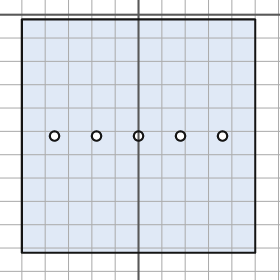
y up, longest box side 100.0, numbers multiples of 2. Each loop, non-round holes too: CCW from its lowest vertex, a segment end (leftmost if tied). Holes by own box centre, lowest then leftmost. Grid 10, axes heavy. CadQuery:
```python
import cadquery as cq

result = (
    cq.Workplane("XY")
    .moveTo(-50.0, -102.0)
    .lineTo(50.0, -102.0)
    .lineTo(50.0, -2.0)
    .lineTo(-50.0, -2.0)
    .close()
    .moveTo(-36.0, -52.0)
    .circle(2.0)
    .moveTo(-18.0, -52.0)
    .circle(2.0)
    .moveTo(0.0, -52.0)
    .circle(2.0)
    .moveTo(18.0, -52.0)
    .circle(2.0)
    .moveTo(36.0, -52.0)
    .circle(2.0)
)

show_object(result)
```